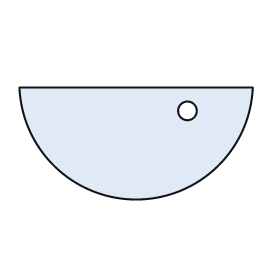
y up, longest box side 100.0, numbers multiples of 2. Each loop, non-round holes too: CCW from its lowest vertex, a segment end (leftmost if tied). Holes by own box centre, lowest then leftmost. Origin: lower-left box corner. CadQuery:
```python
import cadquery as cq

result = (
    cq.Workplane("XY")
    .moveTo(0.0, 48.0)
    .threePointArc((50.0, 0.0), (100.0, 48.0))
    .close()
    .moveTo(72.0, 38.0)
    .circle(4.0)
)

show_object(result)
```